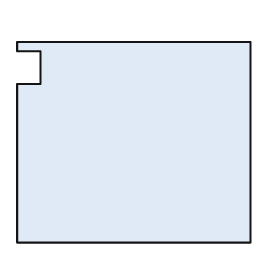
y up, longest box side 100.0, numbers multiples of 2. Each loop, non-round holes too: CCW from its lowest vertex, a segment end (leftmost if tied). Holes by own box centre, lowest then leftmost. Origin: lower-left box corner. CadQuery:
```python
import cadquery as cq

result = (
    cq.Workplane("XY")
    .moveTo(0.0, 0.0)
    .lineTo(100.0, 0.0)
    .lineTo(100.0, 86.0)
    .lineTo(0.0, 86.0)
    .lineTo(0.0, 82.0)
    .lineTo(10.0, 82.0)
    .lineTo(10.0, 68.0)
    .lineTo(0.0, 68.0)
    .close()
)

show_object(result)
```